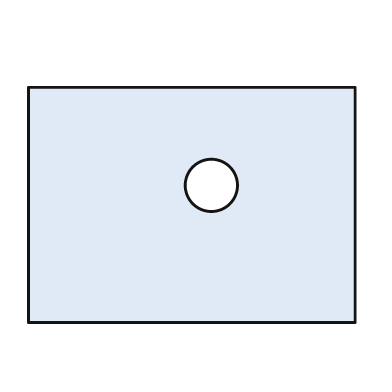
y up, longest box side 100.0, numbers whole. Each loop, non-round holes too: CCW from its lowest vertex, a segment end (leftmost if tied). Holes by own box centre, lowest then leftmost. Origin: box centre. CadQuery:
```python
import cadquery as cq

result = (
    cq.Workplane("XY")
    .moveTo(-50.0, -36.0)
    .lineTo(50.0, -36.0)
    .lineTo(50.0, 36.0)
    .lineTo(-50.0, 36.0)
    .close()
    .moveTo(6.0, 6.0)
    .circle(8.0)
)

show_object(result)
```